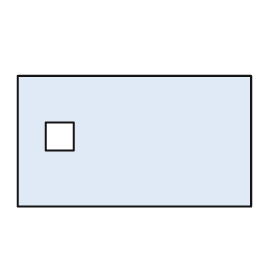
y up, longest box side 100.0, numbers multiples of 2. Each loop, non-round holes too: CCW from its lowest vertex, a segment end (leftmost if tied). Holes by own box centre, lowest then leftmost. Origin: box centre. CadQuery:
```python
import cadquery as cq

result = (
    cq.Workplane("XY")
    .moveTo(-50.0, -28.0)
    .lineTo(50.0, -28.0)
    .lineTo(50.0, 28.0)
    .lineTo(-50.0, 28.0)
    .close()
    .moveTo(-38.0, -4.0)
    .lineTo(-26.0, -4.0)
    .lineTo(-26.0, 8.0)
    .lineTo(-38.0, 8.0)
    .close()
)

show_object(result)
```